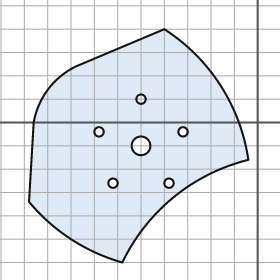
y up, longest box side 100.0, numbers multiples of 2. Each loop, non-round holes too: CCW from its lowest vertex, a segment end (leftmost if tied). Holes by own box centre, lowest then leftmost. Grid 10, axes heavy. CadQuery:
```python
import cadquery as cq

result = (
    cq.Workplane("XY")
    .moveTo(-58.0, -60.0)
    .threePointArc((-36.0, -32.0), (-4.0, -16.0))
    .threePointArc((-16.0, 16.0), (-40.0, 40.0))
    .lineTo(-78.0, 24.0)
    .threePointArc((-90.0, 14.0), (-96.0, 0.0))
    .lineTo(-98.0, -34.0)
    .threePointArc((-80.0, -50.0), (-58.0, -60.0))
    .close()
    .moveTo(-62.0, -26.0)
    .circle(2.0)
    .moveTo(-38.0, -26.0)
    .circle(2.0)
    .moveTo(-50.0, -10.0)
    .circle(4.0)
    .moveTo(-68.0, -4.0)
    .circle(2.0)
    .moveTo(-32.0, -4.0)
    .circle(2.0)
    .moveTo(-50.0, 10.0)
    .circle(2.0)
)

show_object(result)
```